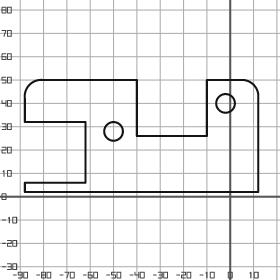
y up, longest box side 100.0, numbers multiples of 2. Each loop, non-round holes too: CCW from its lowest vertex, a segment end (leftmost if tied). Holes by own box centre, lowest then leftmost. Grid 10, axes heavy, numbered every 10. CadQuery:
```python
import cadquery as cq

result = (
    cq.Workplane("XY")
    .moveTo(-88.0, 2.0)
    .lineTo(12.0, 2.0)
    .lineTo(12.0, 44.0)
    .threePointArc((10.0, 48.0), (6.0, 50.0))
    .lineTo(-10.0, 50.0)
    .lineTo(-10.0, 26.0)
    .lineTo(-40.0, 26.0)
    .lineTo(-40.0, 50.0)
    .lineTo(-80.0, 50.0)
    .threePointArc((-86.0, 48.0), (-88.0, 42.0))
    .lineTo(-88.0, 32.0)
    .lineTo(-62.0, 32.0)
    .lineTo(-62.0, 6.0)
    .lineTo(-88.0, 6.0)
    .close()
    .moveTo(-50.0, 28.0)
    .circle(4.0)
    .moveTo(-2.0, 40.0)
    .circle(4.0)
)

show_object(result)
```